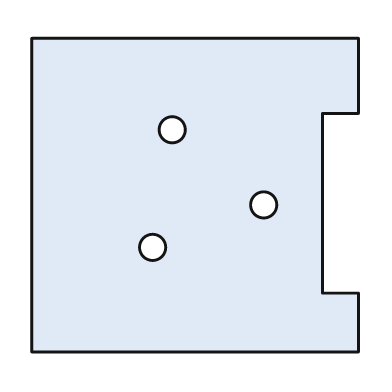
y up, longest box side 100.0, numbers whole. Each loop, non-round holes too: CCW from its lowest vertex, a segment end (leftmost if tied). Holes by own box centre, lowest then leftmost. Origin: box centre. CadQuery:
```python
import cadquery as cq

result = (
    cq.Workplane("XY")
    .moveTo(-50.0, -48.0)
    .lineTo(50.0, -48.0)
    .lineTo(50.0, -30.0)
    .lineTo(39.0, -30.0)
    .lineTo(39.0, 25.0)
    .lineTo(50.0, 25.0)
    .lineTo(50.0, 48.0)
    .lineTo(-50.0, 48.0)
    .close()
    .moveTo(-13.0, -16.0)
    .circle(4.0)
    .moveTo(21.0, -3.0)
    .circle(4.0)
    .moveTo(-7.0, 20.0)
    .circle(4.0)
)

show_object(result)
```